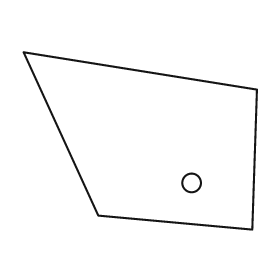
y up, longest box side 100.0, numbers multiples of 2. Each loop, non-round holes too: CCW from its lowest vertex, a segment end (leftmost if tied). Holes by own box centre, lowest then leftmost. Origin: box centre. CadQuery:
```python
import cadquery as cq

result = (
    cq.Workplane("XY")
    .moveTo(48.0, -38.0)
    .lineTo(50.0, 22.0)
    .lineTo(-50.0, 38.0)
    .lineTo(-18.0, -32.0)
    .close()
    .moveTo(22.0, -18.0)
    .circle(4.0)
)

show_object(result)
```